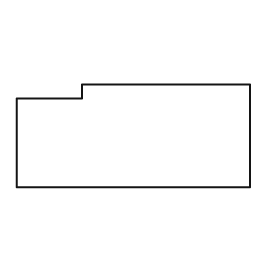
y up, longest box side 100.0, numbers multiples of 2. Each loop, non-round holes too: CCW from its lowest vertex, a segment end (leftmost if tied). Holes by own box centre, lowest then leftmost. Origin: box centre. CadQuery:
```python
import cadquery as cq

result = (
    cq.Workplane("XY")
    .moveTo(-50.0, -22.0)
    .lineTo(50.0, -22.0)
    .lineTo(50.0, 22.0)
    .lineTo(-22.0, 22.0)
    .lineTo(-22.0, 16.0)
    .lineTo(-50.0, 16.0)
    .close()
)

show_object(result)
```